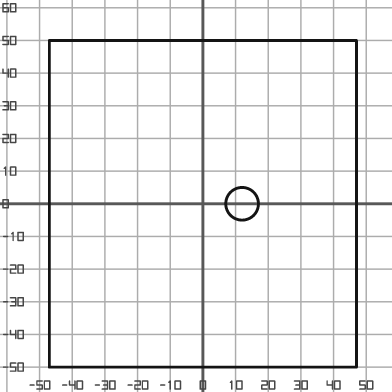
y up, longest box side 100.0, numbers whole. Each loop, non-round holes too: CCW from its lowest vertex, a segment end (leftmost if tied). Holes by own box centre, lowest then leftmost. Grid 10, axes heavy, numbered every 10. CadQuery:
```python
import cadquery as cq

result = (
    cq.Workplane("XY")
    .moveTo(-47.0, -50.0)
    .lineTo(47.0, -50.0)
    .lineTo(47.0, 50.0)
    .lineTo(-47.0, 50.0)
    .close()
    .moveTo(12.0, 0.0)
    .circle(5.0)
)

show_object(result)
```